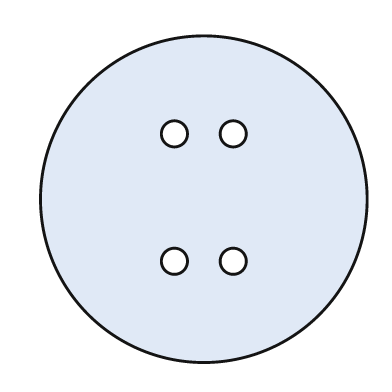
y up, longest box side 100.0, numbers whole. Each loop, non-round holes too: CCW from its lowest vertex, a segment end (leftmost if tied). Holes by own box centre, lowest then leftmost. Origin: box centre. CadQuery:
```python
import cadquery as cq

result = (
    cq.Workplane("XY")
    .moveTo(0.0, 0.0)
    .circle(50.0)
    .moveTo(-9.0, -19.0)
    .circle(4.0)
    .moveTo(9.0, -19.0)
    .circle(4.0)
    .moveTo(-9.0, 20.0)
    .circle(4.0)
    .moveTo(9.0, 20.0)
    .circle(4.0)
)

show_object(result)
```